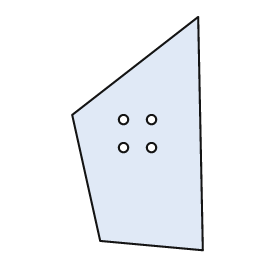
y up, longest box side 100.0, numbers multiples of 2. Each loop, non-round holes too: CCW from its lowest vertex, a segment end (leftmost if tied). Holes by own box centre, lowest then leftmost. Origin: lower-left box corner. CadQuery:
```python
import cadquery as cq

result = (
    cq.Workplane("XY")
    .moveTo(56.0, 0.0)
    .lineTo(54.0, 100.0)
    .lineTo(0.0, 58.0)
    .lineTo(12.0, 4.0)
    .close()
    .moveTo(22.0, 44.0)
    .circle(2.0)
    .moveTo(34.0, 44.0)
    .circle(2.0)
    .moveTo(22.0, 56.0)
    .circle(2.0)
    .moveTo(34.0, 56.0)
    .circle(2.0)
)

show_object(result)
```